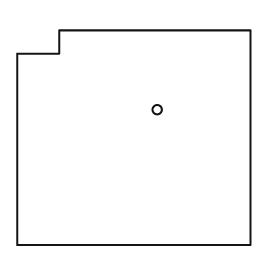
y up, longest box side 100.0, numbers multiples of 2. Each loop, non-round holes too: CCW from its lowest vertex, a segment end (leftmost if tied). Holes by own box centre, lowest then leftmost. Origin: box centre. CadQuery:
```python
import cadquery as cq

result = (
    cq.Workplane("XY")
    .moveTo(-50.0, -46.0)
    .lineTo(50.0, -46.0)
    .lineTo(50.0, 46.0)
    .lineTo(-32.0, 46.0)
    .lineTo(-32.0, 36.0)
    .lineTo(-50.0, 36.0)
    .close()
    .moveTo(10.0, 12.0)
    .circle(2.0)
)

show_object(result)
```